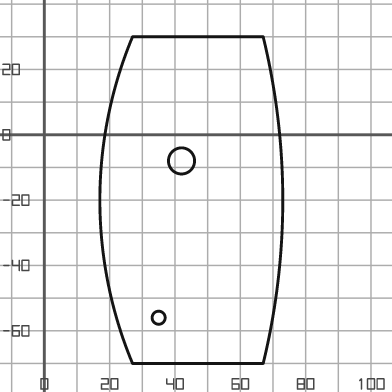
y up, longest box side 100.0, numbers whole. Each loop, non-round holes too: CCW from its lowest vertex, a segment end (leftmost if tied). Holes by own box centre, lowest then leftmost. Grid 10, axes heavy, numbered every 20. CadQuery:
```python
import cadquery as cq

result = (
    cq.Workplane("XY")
    .moveTo(27.0, -70.0)
    .lineTo(67.0, -70.0)
    .threePointArc((73.0, -20.0), (67.0, 30.0))
    .lineTo(27.0, 30.0)
    .threePointArc((17.0, -20.0), (27.0, -70.0))
    .close()
    .moveTo(35.0, -56.0)
    .circle(2.0)
    .moveTo(42.0, -8.0)
    .circle(4.0)
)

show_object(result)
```